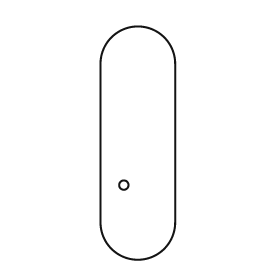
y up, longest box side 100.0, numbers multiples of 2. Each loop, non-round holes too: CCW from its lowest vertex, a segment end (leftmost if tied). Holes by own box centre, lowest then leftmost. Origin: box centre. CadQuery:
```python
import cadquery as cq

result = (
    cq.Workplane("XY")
    .moveTo(-16.0, -34.0)
    .threePointArc((0.0, -50.0), (16.0, -34.0))
    .lineTo(16.0, 34.0)
    .threePointArc((0.0, 50.0), (-16.0, 34.0))
    .close()
    .moveTo(-6.0, -18.0)
    .circle(2.0)
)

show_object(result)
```